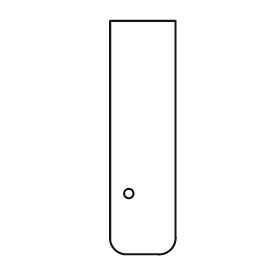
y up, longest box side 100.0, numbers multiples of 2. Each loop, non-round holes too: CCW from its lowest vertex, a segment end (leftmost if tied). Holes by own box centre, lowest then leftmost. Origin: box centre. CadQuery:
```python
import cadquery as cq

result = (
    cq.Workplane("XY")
    .moveTo(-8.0, -50.0)
    .lineTo(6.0, -50.0)
    .threePointArc((12.0, -48.0), (14.0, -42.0))
    .lineTo(14.0, 50.0)
    .lineTo(-14.0, 50.0)
    .lineTo(-14.0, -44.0)
    .threePointArc((-12.0, -48.0), (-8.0, -50.0))
    .close()
    .moveTo(-6.0, -24.0)
    .circle(2.0)
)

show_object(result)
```